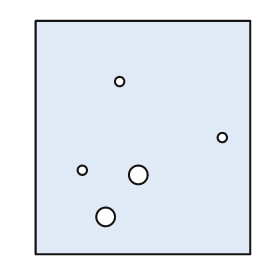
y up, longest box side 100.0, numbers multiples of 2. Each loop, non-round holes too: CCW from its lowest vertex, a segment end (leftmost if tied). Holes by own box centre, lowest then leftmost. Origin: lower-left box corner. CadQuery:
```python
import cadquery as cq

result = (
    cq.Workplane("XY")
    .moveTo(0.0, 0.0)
    .lineTo(92.0, 0.0)
    .lineTo(92.0, 100.0)
    .lineTo(0.0, 100.0)
    .close()
    .moveTo(30.0, 16.0)
    .circle(4.0)
    .moveTo(44.0, 34.0)
    .circle(4.0)
    .moveTo(20.0, 36.0)
    .circle(2.0)
    .moveTo(80.0, 50.0)
    .circle(2.0)
    .moveTo(36.0, 74.0)
    .circle(2.0)
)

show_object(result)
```